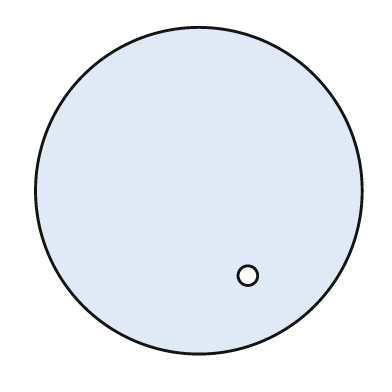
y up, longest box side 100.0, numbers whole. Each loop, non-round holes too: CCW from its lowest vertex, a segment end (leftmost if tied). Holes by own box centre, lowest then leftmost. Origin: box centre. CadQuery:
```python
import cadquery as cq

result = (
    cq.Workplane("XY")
    .moveTo(0.0, 0.0)
    .circle(50.0)
    .moveTo(15.0, -26.0)
    .circle(3.0)
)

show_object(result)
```